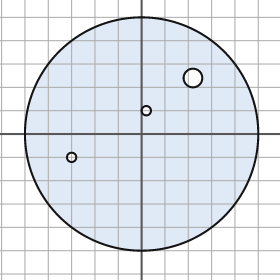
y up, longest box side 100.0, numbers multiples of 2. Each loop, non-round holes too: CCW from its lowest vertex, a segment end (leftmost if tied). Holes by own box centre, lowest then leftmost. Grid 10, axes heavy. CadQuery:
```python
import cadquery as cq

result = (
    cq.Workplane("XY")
    .moveTo(0.0, 0.0)
    .circle(50.0)
    .moveTo(-30.0, -10.0)
    .circle(2.0)
    .moveTo(2.0, 10.0)
    .circle(2.0)
    .moveTo(22.0, 24.0)
    .circle(4.0)
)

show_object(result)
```